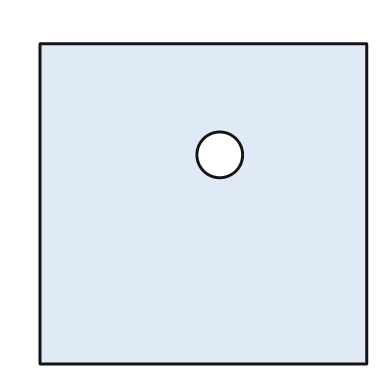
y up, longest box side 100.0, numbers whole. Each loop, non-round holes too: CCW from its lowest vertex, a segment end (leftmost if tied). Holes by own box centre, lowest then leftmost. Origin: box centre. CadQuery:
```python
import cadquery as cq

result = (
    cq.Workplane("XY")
    .moveTo(-50.0, -49.0)
    .lineTo(50.0, -49.0)
    .lineTo(50.0, 49.0)
    .lineTo(-50.0, 49.0)
    .close()
    .moveTo(5.0, 15.0)
    .circle(7.0)
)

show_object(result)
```